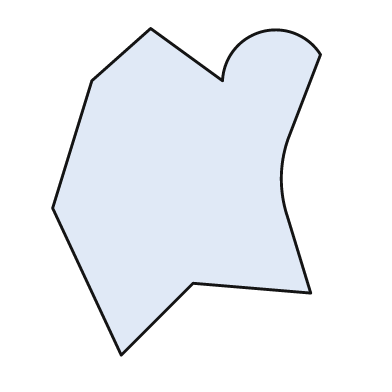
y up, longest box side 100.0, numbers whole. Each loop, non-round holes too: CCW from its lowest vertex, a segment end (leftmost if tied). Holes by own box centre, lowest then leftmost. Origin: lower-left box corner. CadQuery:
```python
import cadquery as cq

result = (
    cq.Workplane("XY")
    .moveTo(21.0, 0.0)
    .lineTo(43.0, 22.0)
    .lineTo(79.0, 19.0)
    .lineTo(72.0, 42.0)
    .threePointArc((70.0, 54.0), (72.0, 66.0))
    .lineTo(82.0, 92.0)
    .threePointArc((64.0, 99.0), (52.0, 84.0))
    .lineTo(30.0, 100.0)
    .lineTo(12.0, 84.0)
    .lineTo(0.0, 45.0)
    .close()
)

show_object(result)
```